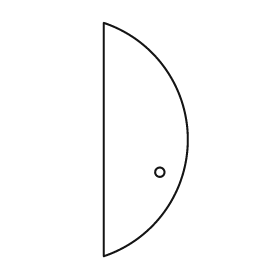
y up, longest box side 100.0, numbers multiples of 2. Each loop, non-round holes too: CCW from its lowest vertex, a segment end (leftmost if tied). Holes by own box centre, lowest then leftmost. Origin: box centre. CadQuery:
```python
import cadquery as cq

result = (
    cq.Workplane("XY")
    .moveTo(-18.0, -50.0)
    .threePointArc((18.0, 0.0), (-18.0, 50.0))
    .close()
    .moveTo(6.0, -14.0)
    .circle(2.0)
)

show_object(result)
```